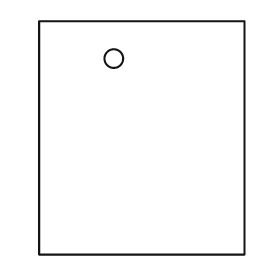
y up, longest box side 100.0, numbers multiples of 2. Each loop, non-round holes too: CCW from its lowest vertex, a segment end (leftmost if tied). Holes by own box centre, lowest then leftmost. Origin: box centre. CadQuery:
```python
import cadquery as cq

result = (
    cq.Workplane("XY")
    .moveTo(-44.0, -50.0)
    .lineTo(44.0, -50.0)
    .lineTo(44.0, 50.0)
    .lineTo(-44.0, 50.0)
    .close()
    .moveTo(-12.0, 34.0)
    .circle(4.0)
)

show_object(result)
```